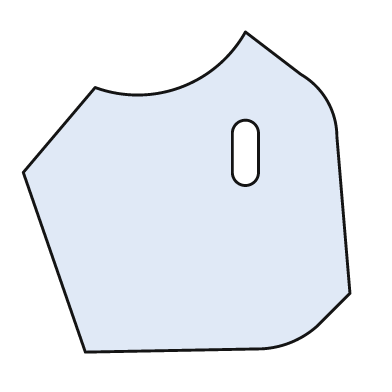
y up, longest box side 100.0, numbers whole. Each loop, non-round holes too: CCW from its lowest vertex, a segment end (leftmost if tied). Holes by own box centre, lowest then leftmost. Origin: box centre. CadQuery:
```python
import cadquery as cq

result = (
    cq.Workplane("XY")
    .moveTo(-31.0, -49.0)
    .lineTo(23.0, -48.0)
    .threePointArc((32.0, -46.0), (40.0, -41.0))
    .lineTo(50.0, -31.0)
    .lineTo(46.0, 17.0)
    .threePointArc((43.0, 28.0), (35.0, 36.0))
    .lineTo(18.0, 49.0)
    .threePointArc((-2.0, 32.0), (-28.0, 32.0))
    .lineTo(-50.0, 6.0)
    .close()
    .moveTo(14.0, 6.0)
    .threePointArc((18.0, 2.0), (22.0, 6.0))
    .lineTo(22.0, 18.0)
    .threePointArc((18.0, 22.0), (14.0, 18.0))
    .close()
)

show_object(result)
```